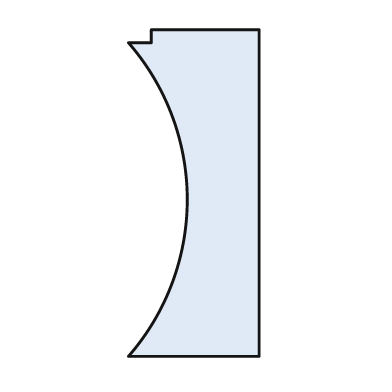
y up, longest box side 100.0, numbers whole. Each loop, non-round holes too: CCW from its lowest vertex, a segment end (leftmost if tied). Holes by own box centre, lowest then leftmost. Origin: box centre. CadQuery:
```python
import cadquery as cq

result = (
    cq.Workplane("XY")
    .moveTo(-20.0, -50.0)
    .lineTo(20.0, -50.0)
    .lineTo(20.0, 50.0)
    .lineTo(-13.0, 50.0)
    .lineTo(-13.0, 46.0)
    .lineTo(-20.0, 46.0)
    .threePointArc((-2.0, -2.0), (-20.0, -50.0))
    .close()
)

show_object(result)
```